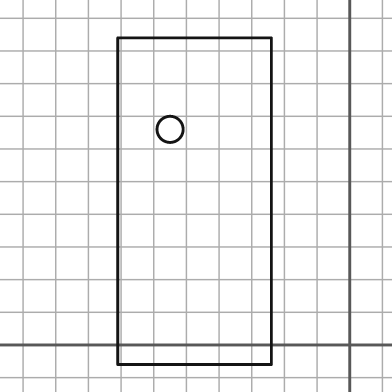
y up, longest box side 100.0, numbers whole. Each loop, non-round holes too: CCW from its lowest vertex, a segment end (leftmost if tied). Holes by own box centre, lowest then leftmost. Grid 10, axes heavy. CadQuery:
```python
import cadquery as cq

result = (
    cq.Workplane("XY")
    .moveTo(-71.0, -6.0)
    .lineTo(-24.0, -6.0)
    .lineTo(-24.0, 94.0)
    .lineTo(-71.0, 94.0)
    .close()
    .moveTo(-55.0, 66.0)
    .circle(4.0)
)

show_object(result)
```